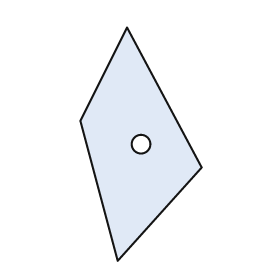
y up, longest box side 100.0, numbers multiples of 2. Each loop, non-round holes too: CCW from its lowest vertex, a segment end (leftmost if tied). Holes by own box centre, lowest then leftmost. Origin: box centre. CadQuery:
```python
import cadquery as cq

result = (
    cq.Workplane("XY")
    .moveTo(-10.0, -50.0)
    .lineTo(26.0, -10.0)
    .lineTo(-6.0, 50.0)
    .lineTo(-26.0, 10.0)
    .close()
    .moveTo(0.0, 0.0)
    .circle(4.0)
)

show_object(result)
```